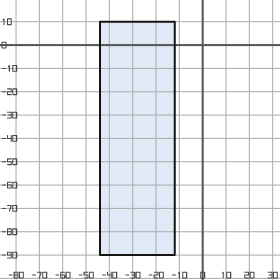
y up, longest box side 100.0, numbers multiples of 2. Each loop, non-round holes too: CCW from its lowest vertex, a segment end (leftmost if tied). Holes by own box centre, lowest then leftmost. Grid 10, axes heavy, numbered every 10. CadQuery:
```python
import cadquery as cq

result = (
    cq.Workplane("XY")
    .moveTo(-44.0, -90.0)
    .lineTo(-12.0, -90.0)
    .lineTo(-12.0, 10.0)
    .lineTo(-44.0, 10.0)
    .close()
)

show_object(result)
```